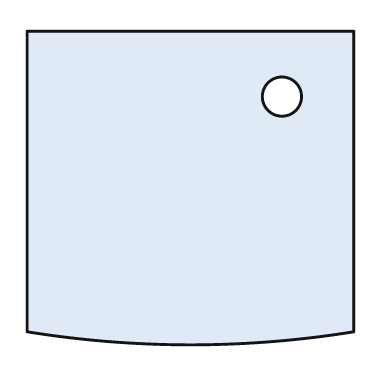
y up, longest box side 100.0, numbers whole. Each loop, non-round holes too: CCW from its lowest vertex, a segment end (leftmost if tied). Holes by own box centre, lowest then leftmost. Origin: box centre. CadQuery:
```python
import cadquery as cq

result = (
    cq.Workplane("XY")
    .moveTo(-50.0, -44.0)
    .threePointArc((0.0, -48.0), (50.0, -44.0))
    .lineTo(50.0, 48.0)
    .lineTo(-50.0, 48.0)
    .close()
    .moveTo(28.0, 28.0)
    .circle(6.0)
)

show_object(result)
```